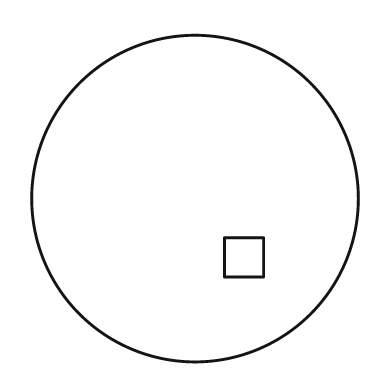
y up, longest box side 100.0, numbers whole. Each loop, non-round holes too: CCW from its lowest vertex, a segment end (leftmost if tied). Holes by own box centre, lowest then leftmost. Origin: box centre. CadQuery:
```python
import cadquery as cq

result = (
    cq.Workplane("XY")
    .moveTo(0.0, 0.0)
    .circle(50.0)
    .moveTo(9.0, -24.0)
    .lineTo(21.0, -24.0)
    .lineTo(21.0, -12.0)
    .lineTo(9.0, -12.0)
    .close()
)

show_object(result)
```